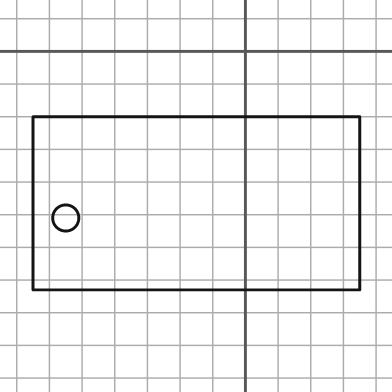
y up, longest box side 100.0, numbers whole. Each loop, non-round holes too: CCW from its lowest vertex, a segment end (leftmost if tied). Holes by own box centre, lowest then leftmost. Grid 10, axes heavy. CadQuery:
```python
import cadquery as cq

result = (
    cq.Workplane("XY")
    .moveTo(-65.0, -73.0)
    .lineTo(35.0, -73.0)
    .lineTo(35.0, -20.0)
    .lineTo(-65.0, -20.0)
    .close()
    .moveTo(-55.0, -51.0)
    .circle(4.0)
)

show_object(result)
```